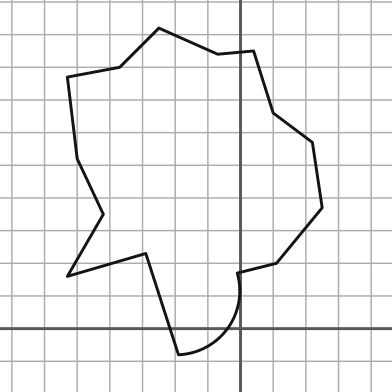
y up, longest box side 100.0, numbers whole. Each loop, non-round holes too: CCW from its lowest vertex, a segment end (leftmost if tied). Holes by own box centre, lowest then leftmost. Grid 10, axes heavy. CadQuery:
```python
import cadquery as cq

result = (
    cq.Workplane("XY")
    .moveTo(-19.0, -8.0)
    .threePointArc((-4.0, 0.0), (-1.0, 17.0))
    .lineTo(11.0, 20.0)
    .lineTo(25.0, 37.0)
    .lineTo(22.0, 57.0)
    .lineTo(10.0, 66.0)
    .lineTo(4.0, 85.0)
    .lineTo(-7.0, 84.0)
    .lineTo(-25.0, 92.0)
    .lineTo(-37.0, 80.0)
    .lineTo(-53.0, 77.0)
    .lineTo(-50.0, 52.0)
    .lineTo(-42.0, 35.0)
    .lineTo(-53.0, 16.0)
    .lineTo(-29.0, 23.0)
    .close()
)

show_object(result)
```